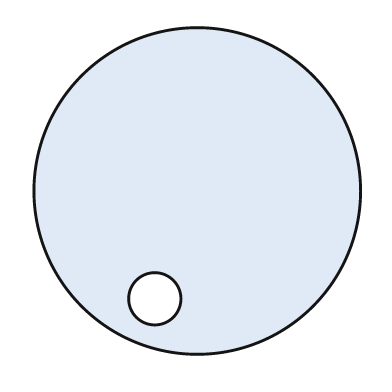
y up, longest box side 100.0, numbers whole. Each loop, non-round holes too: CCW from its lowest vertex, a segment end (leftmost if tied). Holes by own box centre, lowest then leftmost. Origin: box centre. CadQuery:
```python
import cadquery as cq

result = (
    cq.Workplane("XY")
    .moveTo(0.0, 0.0)
    .circle(50.0)
    .moveTo(-13.0, -33.0)
    .circle(8.0)
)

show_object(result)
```